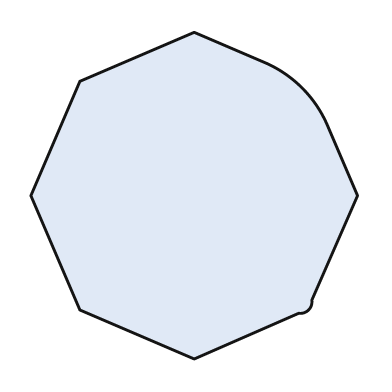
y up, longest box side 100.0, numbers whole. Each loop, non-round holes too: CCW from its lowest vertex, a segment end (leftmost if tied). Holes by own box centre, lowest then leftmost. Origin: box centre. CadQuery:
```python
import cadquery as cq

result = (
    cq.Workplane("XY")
    .moveTo(0.0, -50.0)
    .lineTo(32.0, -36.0)
    .threePointArc((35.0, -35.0), (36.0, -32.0))
    .lineTo(50.0, 0.0)
    .lineTo(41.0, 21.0)
    .threePointArc((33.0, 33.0), (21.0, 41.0))
    .lineTo(0.0, 50.0)
    .lineTo(-35.0, 35.0)
    .lineTo(-50.0, 0.0)
    .lineTo(-35.0, -35.0)
    .close()
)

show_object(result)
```